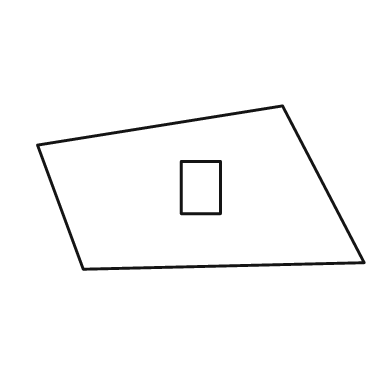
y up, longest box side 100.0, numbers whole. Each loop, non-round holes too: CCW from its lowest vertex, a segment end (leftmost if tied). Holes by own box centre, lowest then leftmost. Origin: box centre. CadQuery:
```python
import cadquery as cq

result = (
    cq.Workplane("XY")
    .moveTo(-36.0, -25.0)
    .lineTo(50.0, -23.0)
    .lineTo(25.0, 25.0)
    .lineTo(-50.0, 13.0)
    .close()
    .moveTo(-6.0, -8.0)
    .lineTo(6.0, -8.0)
    .lineTo(6.0, 8.0)
    .lineTo(-6.0, 8.0)
    .close()
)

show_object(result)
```